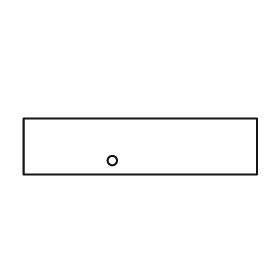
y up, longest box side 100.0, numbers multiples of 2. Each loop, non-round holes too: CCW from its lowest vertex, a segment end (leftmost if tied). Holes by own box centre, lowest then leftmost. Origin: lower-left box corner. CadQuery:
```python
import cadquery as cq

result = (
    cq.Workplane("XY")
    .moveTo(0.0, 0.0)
    .lineTo(100.0, 0.0)
    .lineTo(100.0, 24.0)
    .lineTo(0.0, 24.0)
    .close()
    .moveTo(38.0, 6.0)
    .circle(2.0)
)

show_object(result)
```